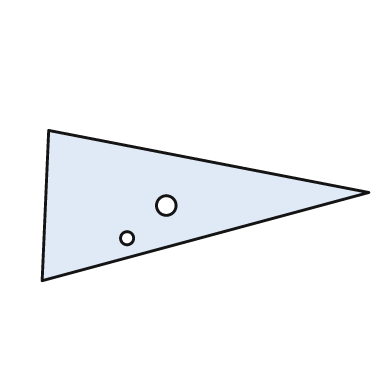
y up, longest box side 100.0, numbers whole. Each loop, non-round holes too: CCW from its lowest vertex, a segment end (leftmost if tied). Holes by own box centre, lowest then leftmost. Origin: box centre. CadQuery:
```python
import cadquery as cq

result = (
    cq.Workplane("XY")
    .moveTo(-50.0, -23.0)
    .lineTo(50.0, 4.0)
    .lineTo(-48.0, 23.0)
    .close()
    .moveTo(-24.0, -10.0)
    .circle(2.0)
    .moveTo(-12.0, 0.0)
    .circle(3.0)
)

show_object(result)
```